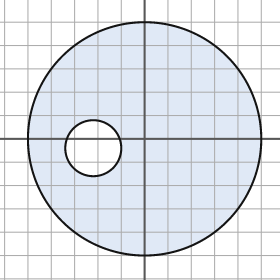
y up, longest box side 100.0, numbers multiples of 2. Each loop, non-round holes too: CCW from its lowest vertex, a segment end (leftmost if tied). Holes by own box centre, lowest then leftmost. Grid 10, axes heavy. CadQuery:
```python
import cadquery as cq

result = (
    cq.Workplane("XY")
    .moveTo(0.0, 0.0)
    .circle(50.0)
    .moveTo(-22.0, -4.0)
    .circle(12.0)
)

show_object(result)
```